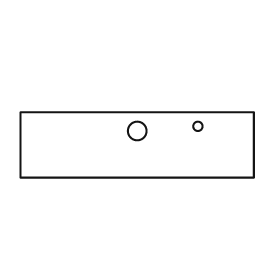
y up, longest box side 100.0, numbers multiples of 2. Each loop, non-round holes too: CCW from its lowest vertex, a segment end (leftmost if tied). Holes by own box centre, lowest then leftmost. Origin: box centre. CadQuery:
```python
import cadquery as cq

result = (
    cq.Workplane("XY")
    .moveTo(-50.0, -14.0)
    .lineTo(50.0, -14.0)
    .lineTo(50.0, 14.0)
    .lineTo(-50.0, 14.0)
    .close()
    .moveTo(0.0, 6.0)
    .circle(4.0)
    .moveTo(26.0, 8.0)
    .circle(2.0)
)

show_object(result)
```